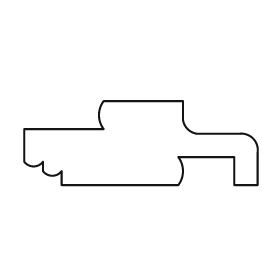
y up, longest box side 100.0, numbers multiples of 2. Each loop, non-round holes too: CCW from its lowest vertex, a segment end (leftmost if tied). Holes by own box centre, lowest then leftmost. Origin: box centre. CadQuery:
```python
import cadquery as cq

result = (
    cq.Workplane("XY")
    .moveTo(-34.0, -18.0)
    .lineTo(16.0, -18.0)
    .threePointArc((18.0, -12.0), (16.0, -6.0))
    .lineTo(40.0, -6.0)
    .lineTo(40.0, -18.0)
    .lineTo(50.0, -18.0)
    .lineTo(50.0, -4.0)
    .threePointArc((48.0, 2.0), (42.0, 4.0))
    .lineTo(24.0, 4.0)
    .threePointArc((20.0, 6.0), (18.0, 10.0))
    .lineTo(18.0, 18.0)
    .lineTo(-16.0, 18.0)
    .threePointArc((-18.0, 12.0), (-16.0, 6.0))
    .lineTo(-50.0, 6.0)
    .lineTo(-50.0, -8.0)
    .threePointArc((-46.0, -10.0), (-42.0, -8.0))
    .lineTo(-42.0, -12.0)
    .threePointArc((-38.0, -14.0), (-34.0, -12.0))
    .close()
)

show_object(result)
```